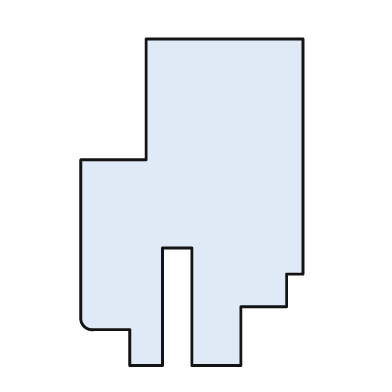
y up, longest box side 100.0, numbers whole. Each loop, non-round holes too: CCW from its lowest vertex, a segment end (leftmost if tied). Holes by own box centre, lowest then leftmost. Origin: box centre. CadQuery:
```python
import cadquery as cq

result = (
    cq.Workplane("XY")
    .moveTo(-19.0, -50.0)
    .lineTo(-9.0, -50.0)
    .lineTo(-9.0, -14.0)
    .lineTo(0.0, -14.0)
    .lineTo(0.0, -50.0)
    .lineTo(15.0, -50.0)
    .lineTo(15.0, -32.0)
    .lineTo(29.0, -32.0)
    .lineTo(29.0, -22.0)
    .lineTo(34.0, -22.0)
    .lineTo(34.0, 50.0)
    .lineTo(-14.0, 50.0)
    .lineTo(-14.0, 13.0)
    .lineTo(-34.0, 13.0)
    .lineTo(-34.0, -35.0)
    .threePointArc((-33.0, -38.0), (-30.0, -39.0))
    .lineTo(-19.0, -39.0)
    .close()
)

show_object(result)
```